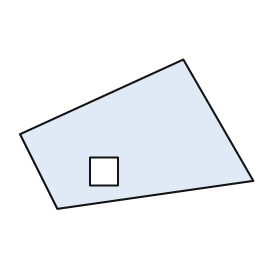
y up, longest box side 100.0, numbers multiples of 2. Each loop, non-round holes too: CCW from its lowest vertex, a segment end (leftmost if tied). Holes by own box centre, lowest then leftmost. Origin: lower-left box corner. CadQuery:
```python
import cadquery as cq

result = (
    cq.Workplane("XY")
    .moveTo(16.0, 0.0)
    .lineTo(100.0, 12.0)
    .lineTo(70.0, 64.0)
    .lineTo(0.0, 32.0)
    .close()
    .moveTo(30.0, 10.0)
    .lineTo(42.0, 10.0)
    .lineTo(42.0, 22.0)
    .lineTo(30.0, 22.0)
    .close()
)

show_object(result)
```